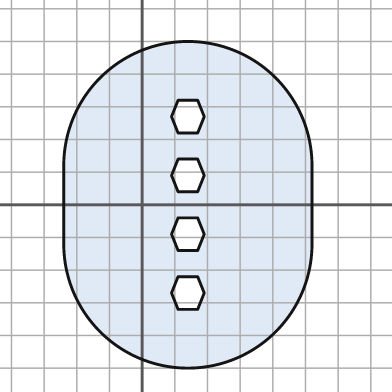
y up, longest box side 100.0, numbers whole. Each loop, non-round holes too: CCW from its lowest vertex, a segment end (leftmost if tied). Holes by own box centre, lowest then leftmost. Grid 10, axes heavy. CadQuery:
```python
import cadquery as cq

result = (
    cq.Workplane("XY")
    .moveTo(-24.0, -12.0)
    .threePointArc((14.0, -50.0), (52.0, -12.0))
    .lineTo(52.0, 12.0)
    .threePointArc((14.0, 50.0), (-24.0, 12.0))
    .close()
    .moveTo(11.0, -32.0)
    .lineTo(17.0, -32.0)
    .lineTo(19.0, -27.0)
    .lineTo(17.0, -22.0)
    .lineTo(11.0, -22.0)
    .lineTo(9.0, -27.0)
    .close()
    .moveTo(11.0, -14.0)
    .lineTo(17.0, -14.0)
    .lineTo(19.0, -9.0)
    .lineTo(17.0, -4.0)
    .lineTo(11.0, -4.0)
    .lineTo(9.0, -9.0)
    .close()
    .moveTo(11.0, 4.0)
    .lineTo(17.0, 4.0)
    .lineTo(19.0, 9.0)
    .lineTo(17.0, 14.0)
    .lineTo(11.0, 14.0)
    .lineTo(9.0, 9.0)
    .close()
    .moveTo(11.0, 22.0)
    .lineTo(17.0, 22.0)
    .lineTo(19.0, 27.0)
    .lineTo(17.0, 32.0)
    .lineTo(11.0, 32.0)
    .lineTo(9.0, 27.0)
    .close()
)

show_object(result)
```